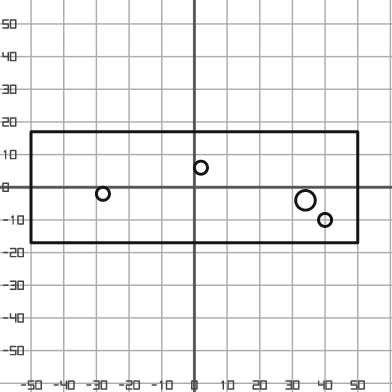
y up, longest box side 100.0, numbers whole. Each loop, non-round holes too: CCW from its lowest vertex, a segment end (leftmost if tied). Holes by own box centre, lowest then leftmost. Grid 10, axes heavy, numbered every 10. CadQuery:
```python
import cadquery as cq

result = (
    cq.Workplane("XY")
    .moveTo(-50.0, -17.0)
    .lineTo(50.0, -17.0)
    .lineTo(50.0, 17.0)
    .lineTo(-50.0, 17.0)
    .close()
    .moveTo(40.0, -10.0)
    .circle(2.0)
    .moveTo(34.0, -4.0)
    .circle(3.0)
    .moveTo(-28.0, -2.0)
    .circle(2.0)
    .moveTo(2.0, 6.0)
    .circle(2.0)
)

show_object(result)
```